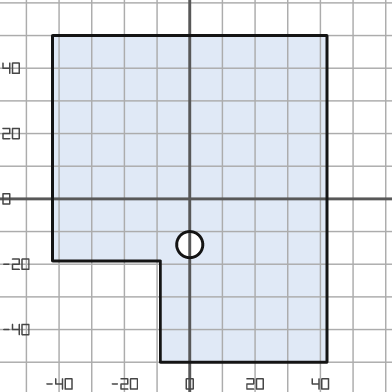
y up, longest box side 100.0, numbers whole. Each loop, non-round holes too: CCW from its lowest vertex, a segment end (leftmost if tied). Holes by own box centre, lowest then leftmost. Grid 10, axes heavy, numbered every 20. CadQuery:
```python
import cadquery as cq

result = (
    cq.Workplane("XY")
    .moveTo(-9.0, -50.0)
    .lineTo(42.0, -50.0)
    .lineTo(42.0, 50.0)
    .lineTo(-42.0, 50.0)
    .lineTo(-42.0, -19.0)
    .lineTo(-9.0, -19.0)
    .close()
    .moveTo(0.0, -14.0)
    .circle(4.0)
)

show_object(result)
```